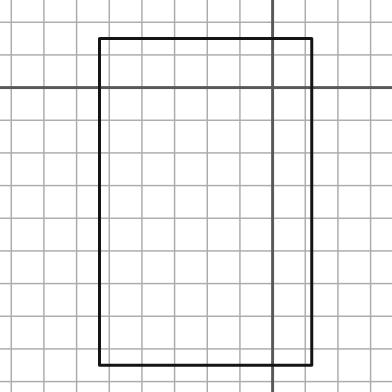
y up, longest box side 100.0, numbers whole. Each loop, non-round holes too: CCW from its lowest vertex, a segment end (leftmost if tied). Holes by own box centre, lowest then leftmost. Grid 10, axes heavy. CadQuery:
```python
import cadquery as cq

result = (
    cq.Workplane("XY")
    .moveTo(-53.0, -85.0)
    .lineTo(12.0, -85.0)
    .lineTo(12.0, 15.0)
    .lineTo(-53.0, 15.0)
    .close()
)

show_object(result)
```